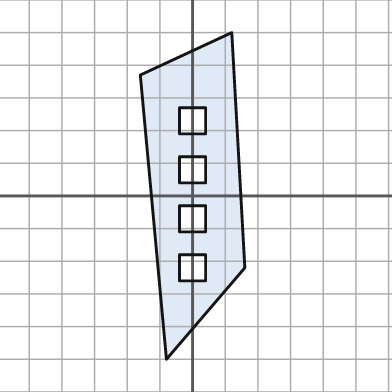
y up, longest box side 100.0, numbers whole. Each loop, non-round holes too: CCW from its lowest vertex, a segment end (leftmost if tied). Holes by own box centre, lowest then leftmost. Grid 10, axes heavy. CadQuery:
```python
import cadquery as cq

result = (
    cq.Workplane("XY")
    .moveTo(-8.0, -50.0)
    .lineTo(16.0, -22.0)
    .lineTo(12.0, 50.0)
    .lineTo(-16.0, 37.0)
    .close()
    .moveTo(-4.0, -26.0)
    .lineTo(4.0, -26.0)
    .lineTo(4.0, -18.0)
    .lineTo(-4.0, -18.0)
    .close()
    .moveTo(-4.0, -11.0)
    .lineTo(4.0, -11.0)
    .lineTo(4.0, -3.0)
    .lineTo(-4.0, -3.0)
    .close()
    .moveTo(-4.0, 4.0)
    .lineTo(4.0, 4.0)
    .lineTo(4.0, 12.0)
    .lineTo(-4.0, 12.0)
    .close()
    .moveTo(-4.0, 19.0)
    .lineTo(4.0, 19.0)
    .lineTo(4.0, 27.0)
    .lineTo(-4.0, 27.0)
    .close()
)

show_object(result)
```